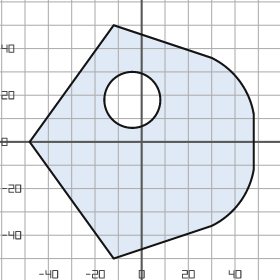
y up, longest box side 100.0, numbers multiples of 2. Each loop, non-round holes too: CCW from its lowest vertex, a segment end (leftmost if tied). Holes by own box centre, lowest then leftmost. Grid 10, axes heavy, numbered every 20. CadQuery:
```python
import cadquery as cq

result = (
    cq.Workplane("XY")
    .moveTo(-12.0, -50.0)
    .lineTo(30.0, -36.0)
    .threePointArc((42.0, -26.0), (48.0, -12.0))
    .lineTo(48.0, 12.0)
    .threePointArc((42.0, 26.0), (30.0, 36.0))
    .lineTo(-12.0, 50.0)
    .lineTo(-48.0, 0.0)
    .close()
    .moveTo(-4.0, 18.0)
    .circle(12.0)
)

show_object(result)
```